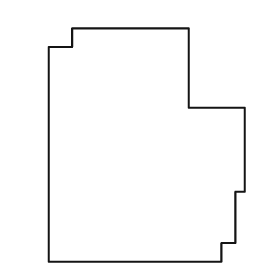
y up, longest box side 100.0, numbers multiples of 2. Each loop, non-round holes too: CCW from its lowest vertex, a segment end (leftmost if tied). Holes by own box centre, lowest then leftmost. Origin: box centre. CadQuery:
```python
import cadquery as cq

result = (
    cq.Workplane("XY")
    .moveTo(-42.0, -50.0)
    .lineTo(32.0, -50.0)
    .lineTo(32.0, -42.0)
    .lineTo(38.0, -42.0)
    .lineTo(38.0, -20.0)
    .lineTo(42.0, -20.0)
    .lineTo(42.0, 16.0)
    .lineTo(18.0, 16.0)
    .lineTo(18.0, 50.0)
    .lineTo(-32.0, 50.0)
    .lineTo(-32.0, 42.0)
    .lineTo(-42.0, 42.0)
    .close()
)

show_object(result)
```